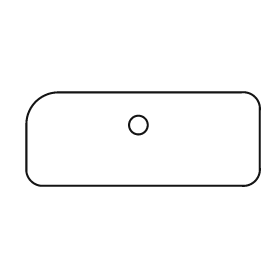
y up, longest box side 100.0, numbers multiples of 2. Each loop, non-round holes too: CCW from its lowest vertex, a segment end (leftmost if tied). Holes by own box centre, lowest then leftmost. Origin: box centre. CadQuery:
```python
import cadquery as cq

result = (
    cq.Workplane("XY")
    .moveTo(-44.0, -20.0)
    .lineTo(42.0, -20.0)
    .threePointArc((48.0, -18.0), (50.0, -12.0))
    .lineTo(50.0, 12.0)
    .threePointArc((48.0, 18.0), (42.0, 20.0))
    .lineTo(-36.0, 20.0)
    .threePointArc((-46.0, 16.0), (-50.0, 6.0))
    .lineTo(-50.0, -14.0)
    .threePointArc((-48.0, -18.0), (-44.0, -20.0))
    .close()
    .moveTo(-2.0, 6.0)
    .circle(4.0)
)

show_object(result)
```